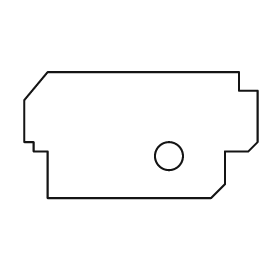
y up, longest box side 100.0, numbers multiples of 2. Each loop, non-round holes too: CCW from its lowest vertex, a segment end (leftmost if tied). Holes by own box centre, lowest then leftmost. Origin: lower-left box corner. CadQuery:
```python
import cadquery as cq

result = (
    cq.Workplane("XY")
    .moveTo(10.0, 0.0)
    .lineTo(80.0, 0.0)
    .lineTo(86.0, 6.0)
    .lineTo(86.0, 20.0)
    .lineTo(96.0, 20.0)
    .lineTo(100.0, 24.0)
    .lineTo(100.0, 46.0)
    .lineTo(92.0, 46.0)
    .lineTo(92.0, 54.0)
    .lineTo(10.0, 54.0)
    .lineTo(0.0, 42.0)
    .lineTo(0.0, 24.0)
    .lineTo(4.0, 24.0)
    .lineTo(4.0, 20.0)
    .lineTo(10.0, 20.0)
    .close()
    .moveTo(62.0, 18.0)
    .circle(6.0)
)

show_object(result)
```